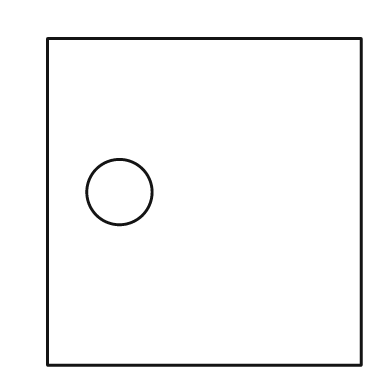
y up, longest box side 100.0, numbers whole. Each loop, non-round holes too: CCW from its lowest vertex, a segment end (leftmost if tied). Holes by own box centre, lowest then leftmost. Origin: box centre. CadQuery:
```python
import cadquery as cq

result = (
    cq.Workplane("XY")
    .moveTo(-48.0, -50.0)
    .lineTo(48.0, -50.0)
    .lineTo(48.0, 50.0)
    .lineTo(-48.0, 50.0)
    .close()
    .moveTo(-26.0, 3.0)
    .circle(10.0)
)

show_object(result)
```